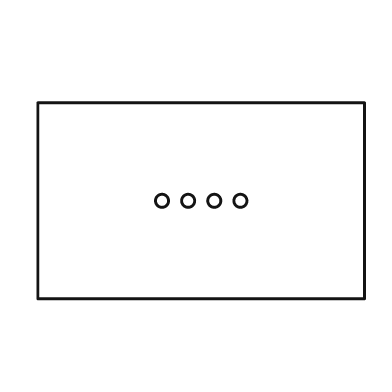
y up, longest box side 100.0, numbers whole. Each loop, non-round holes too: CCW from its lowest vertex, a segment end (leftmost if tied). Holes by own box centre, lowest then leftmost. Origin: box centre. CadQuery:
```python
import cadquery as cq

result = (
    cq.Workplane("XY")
    .moveTo(-50.0, -30.0)
    .lineTo(50.0, -30.0)
    .lineTo(50.0, 30.0)
    .lineTo(-50.0, 30.0)
    .close()
    .moveTo(-12.0, 0.0)
    .circle(2.0)
    .moveTo(-4.0, 0.0)
    .circle(2.0)
    .moveTo(4.0, 0.0)
    .circle(2.0)
    .moveTo(12.0, 0.0)
    .circle(2.0)
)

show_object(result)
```